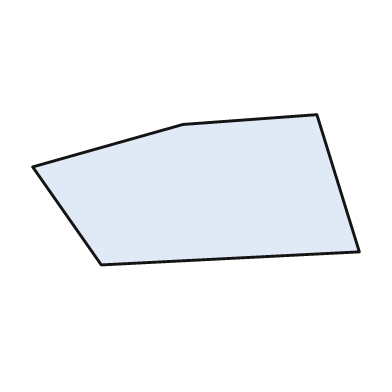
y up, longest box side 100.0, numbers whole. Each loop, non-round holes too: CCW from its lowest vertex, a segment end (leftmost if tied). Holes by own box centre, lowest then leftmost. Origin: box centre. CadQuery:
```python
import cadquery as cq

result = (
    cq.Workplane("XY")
    .moveTo(-29.0, -23.0)
    .lineTo(50.0, -19.0)
    .lineTo(37.0, 23.0)
    .lineTo(-4.0, 20.0)
    .lineTo(-50.0, 7.0)
    .close()
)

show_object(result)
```